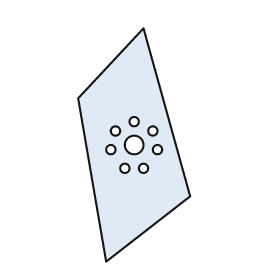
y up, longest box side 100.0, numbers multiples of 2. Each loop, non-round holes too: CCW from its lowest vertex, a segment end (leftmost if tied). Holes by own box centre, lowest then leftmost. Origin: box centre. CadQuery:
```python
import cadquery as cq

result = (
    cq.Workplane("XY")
    .moveTo(-12.0, -50.0)
    .lineTo(24.0, -22.0)
    .lineTo(4.0, 50.0)
    .lineTo(-24.0, 20.0)
    .close()
    .moveTo(-4.0, -10.0)
    .circle(2.0)
    .moveTo(4.0, -10.0)
    .circle(2.0)
    .moveTo(-10.0, -2.0)
    .circle(2.0)
    .moveTo(10.0, -2.0)
    .circle(2.0)
    .moveTo(0.0, 0.0)
    .circle(4.0)
    .moveTo(-8.0, 6.0)
    .circle(2.0)
    .moveTo(8.0, 6.0)
    .circle(2.0)
    .moveTo(0.0, 10.0)
    .circle(2.0)
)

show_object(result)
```